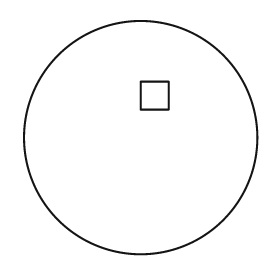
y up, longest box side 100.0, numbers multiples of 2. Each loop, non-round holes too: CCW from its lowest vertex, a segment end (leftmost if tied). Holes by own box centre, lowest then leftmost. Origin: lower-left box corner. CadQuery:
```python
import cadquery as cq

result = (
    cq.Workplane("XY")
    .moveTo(50.0, 50.0)
    .circle(50.0)
    .moveTo(50.0, 62.0)
    .lineTo(62.0, 62.0)
    .lineTo(62.0, 74.0)
    .lineTo(50.0, 74.0)
    .close()
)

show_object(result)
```